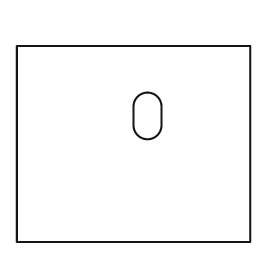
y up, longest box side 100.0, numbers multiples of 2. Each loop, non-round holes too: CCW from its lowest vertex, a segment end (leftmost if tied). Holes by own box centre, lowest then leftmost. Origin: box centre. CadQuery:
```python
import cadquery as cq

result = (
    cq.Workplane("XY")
    .moveTo(-50.0, -42.0)
    .lineTo(50.0, -42.0)
    .lineTo(50.0, 42.0)
    .lineTo(-50.0, 42.0)
    .close()
    .moveTo(0.0, 8.0)
    .threePointArc((6.0, 2.0), (12.0, 8.0))
    .lineTo(12.0, 16.0)
    .threePointArc((6.0, 22.0), (0.0, 16.0))
    .close()
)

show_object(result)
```